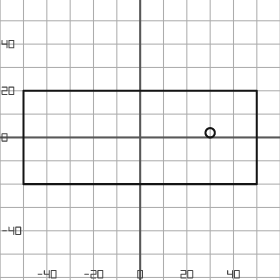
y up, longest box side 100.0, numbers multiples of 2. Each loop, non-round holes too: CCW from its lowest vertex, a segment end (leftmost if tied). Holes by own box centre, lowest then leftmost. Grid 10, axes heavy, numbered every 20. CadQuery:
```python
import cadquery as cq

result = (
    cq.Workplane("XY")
    .moveTo(-50.0, -20.0)
    .lineTo(50.0, -20.0)
    .lineTo(50.0, 20.0)
    .lineTo(-50.0, 20.0)
    .close()
    .moveTo(30.0, 2.0)
    .circle(2.0)
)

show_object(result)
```